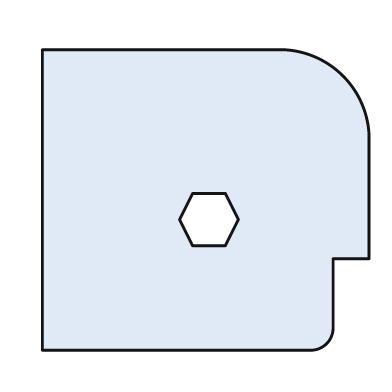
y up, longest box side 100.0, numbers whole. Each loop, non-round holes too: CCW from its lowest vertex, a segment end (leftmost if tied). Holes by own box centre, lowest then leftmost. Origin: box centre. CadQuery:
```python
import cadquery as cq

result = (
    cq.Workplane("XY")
    .moveTo(-50.0, -46.0)
    .lineTo(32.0, -46.0)
    .threePointArc((37.0, -44.0), (39.0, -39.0))
    .lineTo(39.0, -18.0)
    .lineTo(50.0, -18.0)
    .lineTo(50.0, 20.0)
    .threePointArc((42.0, 38.0), (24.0, 46.0))
    .lineTo(-50.0, 46.0)
    .close()
    .moveTo(-4.0, -14.0)
    .lineTo(6.0, -14.0)
    .lineTo(10.0, -6.0)
    .lineTo(6.0, 2.0)
    .lineTo(-4.0, 2.0)
    .lineTo(-8.0, -6.0)
    .close()
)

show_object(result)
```